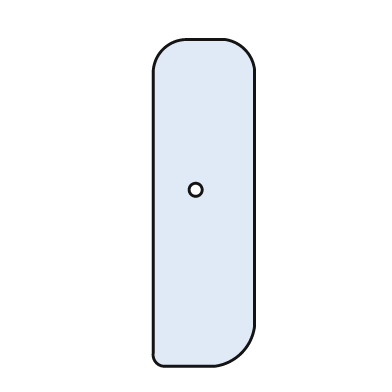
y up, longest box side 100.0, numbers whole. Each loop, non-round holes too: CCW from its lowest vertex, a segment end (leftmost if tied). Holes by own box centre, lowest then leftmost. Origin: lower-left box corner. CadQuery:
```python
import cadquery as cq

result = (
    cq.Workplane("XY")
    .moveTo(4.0, 0.0)
    .lineTo(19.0, 0.0)
    .threePointArc((27.0, 4.0), (31.0, 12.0))
    .lineTo(31.0, 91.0)
    .threePointArc((28.0, 97.0), (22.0, 100.0))
    .lineTo(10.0, 100.0)
    .threePointArc((3.0, 97.0), (0.0, 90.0))
    .lineTo(0.0, 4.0)
    .threePointArc((1.0, 1.0), (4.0, 0.0))
    .close()
    .moveTo(13.0, 54.0)
    .circle(2.0)
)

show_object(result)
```